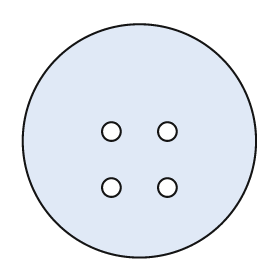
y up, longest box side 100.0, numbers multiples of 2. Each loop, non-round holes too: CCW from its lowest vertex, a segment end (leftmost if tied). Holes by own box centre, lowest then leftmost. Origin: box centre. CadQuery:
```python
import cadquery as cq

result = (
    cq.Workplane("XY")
    .moveTo(0.0, 0.0)
    .circle(50.0)
    .moveTo(-12.0, -20.0)
    .circle(4.0)
    .moveTo(12.0, -20.0)
    .circle(4.0)
    .moveTo(-12.0, 4.0)
    .circle(4.0)
    .moveTo(12.0, 4.0)
    .circle(4.0)
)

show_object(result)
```